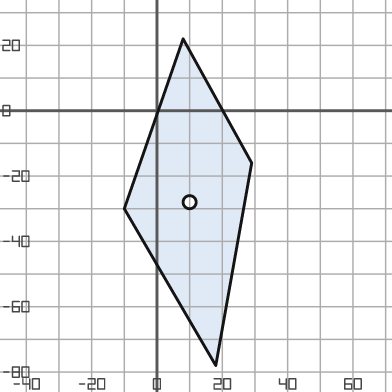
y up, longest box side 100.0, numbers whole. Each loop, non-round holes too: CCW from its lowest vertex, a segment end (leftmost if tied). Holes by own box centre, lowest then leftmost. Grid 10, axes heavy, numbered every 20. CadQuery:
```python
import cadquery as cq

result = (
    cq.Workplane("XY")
    .moveTo(18.0, -78.0)
    .lineTo(29.0, -16.0)
    .lineTo(8.0, 22.0)
    .lineTo(-10.0, -30.0)
    .close()
    .moveTo(10.0, -28.0)
    .circle(2.0)
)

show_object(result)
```